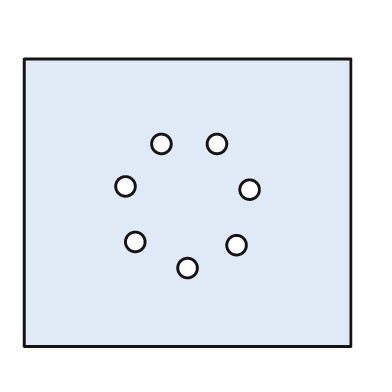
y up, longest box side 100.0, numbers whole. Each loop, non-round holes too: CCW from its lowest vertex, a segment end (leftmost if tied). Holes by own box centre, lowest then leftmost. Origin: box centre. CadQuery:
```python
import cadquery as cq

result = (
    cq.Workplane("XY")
    .moveTo(-50.0, -44.0)
    .lineTo(50.0, -44.0)
    .lineTo(50.0, 44.0)
    .lineTo(-50.0, 44.0)
    .close()
    .moveTo(0.0, -20.0)
    .circle(3.0)
    .moveTo(15.0, -13.0)
    .circle(3.0)
    .moveTo(-16.0, -12.0)
    .circle(3.0)
    .moveTo(19.0, 4.0)
    .circle(3.0)
    .moveTo(-19.0, 5.0)
    .circle(3.0)
    .moveTo(-8.0, 18.0)
    .circle(3.0)
    .moveTo(9.0, 18.0)
    .circle(3.0)
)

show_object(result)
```